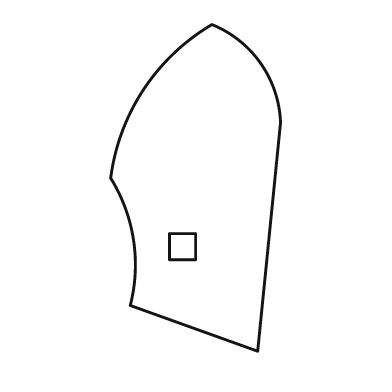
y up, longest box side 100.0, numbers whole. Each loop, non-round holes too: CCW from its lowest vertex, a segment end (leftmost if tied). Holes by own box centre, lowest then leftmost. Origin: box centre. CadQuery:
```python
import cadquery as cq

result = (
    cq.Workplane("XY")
    .moveTo(19.0, -50.0)
    .lineTo(26.0, 20.0)
    .threePointArc((20.0, 38.0), (5.0, 50.0))
    .threePointArc((-16.0, 30.0), (-26.0, 3.0))
    .threePointArc((-19.0, -16.0), (-20.0, -36.0))
    .close()
    .moveTo(-8.0, -22.0)
    .lineTo(0.0, -22.0)
    .lineTo(0.0, -14.0)
    .lineTo(-8.0, -14.0)
    .close()
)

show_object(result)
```